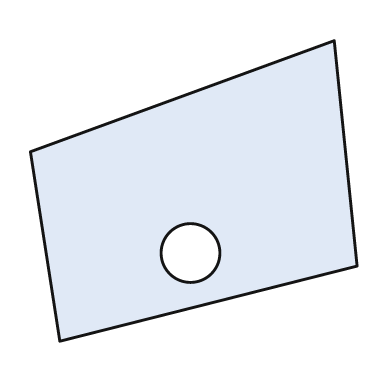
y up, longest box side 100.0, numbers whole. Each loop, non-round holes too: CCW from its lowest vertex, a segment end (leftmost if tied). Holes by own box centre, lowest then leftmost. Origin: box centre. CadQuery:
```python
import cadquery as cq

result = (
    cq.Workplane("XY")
    .moveTo(-41.0, -46.0)
    .lineTo(50.0, -23.0)
    .lineTo(43.0, 46.0)
    .lineTo(-50.0, 12.0)
    .close()
    .moveTo(-1.0, -19.0)
    .circle(9.0)
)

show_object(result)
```